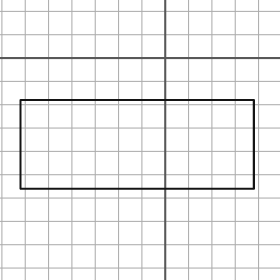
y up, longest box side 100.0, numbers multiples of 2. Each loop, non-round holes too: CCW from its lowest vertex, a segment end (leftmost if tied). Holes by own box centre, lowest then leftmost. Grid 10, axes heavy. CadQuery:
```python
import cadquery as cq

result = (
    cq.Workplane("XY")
    .moveTo(-62.0, -56.0)
    .lineTo(38.0, -56.0)
    .lineTo(38.0, -18.0)
    .lineTo(-62.0, -18.0)
    .close()
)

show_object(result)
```